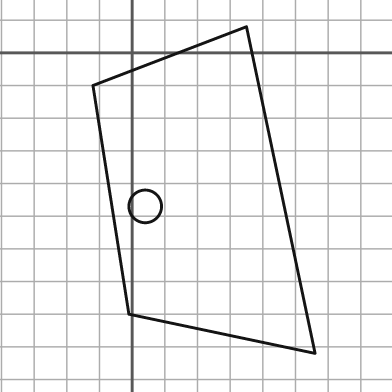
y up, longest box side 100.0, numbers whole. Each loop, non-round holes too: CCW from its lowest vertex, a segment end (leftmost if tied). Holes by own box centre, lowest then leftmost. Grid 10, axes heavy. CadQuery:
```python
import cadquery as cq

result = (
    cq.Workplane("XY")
    .moveTo(56.0, -92.0)
    .lineTo(35.0, 8.0)
    .lineTo(-12.0, -10.0)
    .lineTo(-1.0, -80.0)
    .close()
    .moveTo(4.0, -47.0)
    .circle(5.0)
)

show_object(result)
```